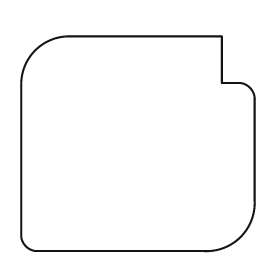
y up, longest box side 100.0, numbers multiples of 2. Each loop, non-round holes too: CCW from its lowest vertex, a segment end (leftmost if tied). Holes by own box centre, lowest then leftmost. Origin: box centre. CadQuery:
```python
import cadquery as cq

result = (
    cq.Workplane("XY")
    .moveTo(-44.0, -46.0)
    .lineTo(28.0, -46.0)
    .threePointArc((44.0, -40.0), (50.0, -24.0))
    .lineTo(50.0, 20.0)
    .threePointArc((48.0, 24.0), (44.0, 26.0))
    .lineTo(36.0, 26.0)
    .lineTo(36.0, 46.0)
    .lineTo(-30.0, 46.0)
    .threePointArc((-44.0, 40.0), (-50.0, 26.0))
    .lineTo(-50.0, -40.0)
    .threePointArc((-48.0, -44.0), (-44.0, -46.0))
    .close()
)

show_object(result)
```